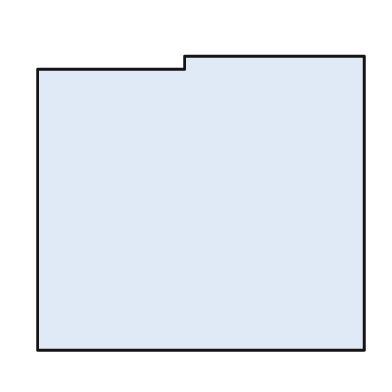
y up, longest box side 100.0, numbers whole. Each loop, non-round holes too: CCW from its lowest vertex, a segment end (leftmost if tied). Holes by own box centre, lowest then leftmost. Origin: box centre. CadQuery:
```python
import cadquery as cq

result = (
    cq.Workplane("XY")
    .moveTo(-50.0, -45.0)
    .lineTo(50.0, -45.0)
    .lineTo(50.0, 45.0)
    .lineTo(-5.0, 45.0)
    .lineTo(-5.0, 41.0)
    .lineTo(-50.0, 41.0)
    .close()
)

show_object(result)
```